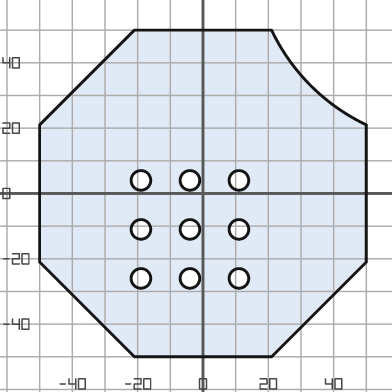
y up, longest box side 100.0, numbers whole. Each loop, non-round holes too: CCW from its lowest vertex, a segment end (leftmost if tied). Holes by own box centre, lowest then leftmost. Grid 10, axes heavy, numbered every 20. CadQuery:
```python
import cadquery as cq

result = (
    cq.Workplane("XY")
    .moveTo(-21.0, -50.0)
    .lineTo(21.0, -50.0)
    .lineTo(50.0, -21.0)
    .lineTo(50.0, 21.0)
    .threePointArc((33.0, 33.0), (21.0, 50.0))
    .lineTo(-21.0, 50.0)
    .lineTo(-50.0, 21.0)
    .lineTo(-50.0, -21.0)
    .close()
    .moveTo(-19.0, -26.0)
    .circle(3.0)
    .moveTo(-4.0, -26.0)
    .circle(3.0)
    .moveTo(11.0, -26.0)
    .circle(3.0)
    .moveTo(-19.0, -11.0)
    .circle(3.0)
    .moveTo(-4.0, -11.0)
    .circle(3.0)
    .moveTo(11.0, -11.0)
    .circle(3.0)
    .moveTo(-19.0, 4.0)
    .circle(3.0)
    .moveTo(-4.0, 4.0)
    .circle(3.0)
    .moveTo(11.0, 4.0)
    .circle(3.0)
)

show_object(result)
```